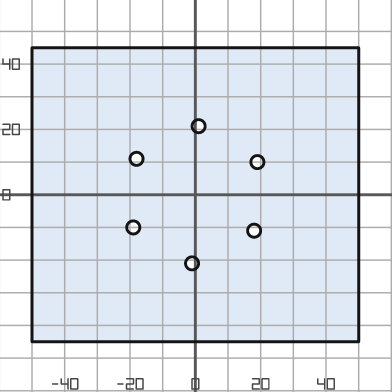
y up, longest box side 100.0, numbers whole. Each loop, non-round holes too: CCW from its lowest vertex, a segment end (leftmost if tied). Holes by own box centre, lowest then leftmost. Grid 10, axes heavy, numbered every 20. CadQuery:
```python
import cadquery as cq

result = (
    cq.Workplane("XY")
    .moveTo(-50.0, -45.0)
    .lineTo(50.0, -45.0)
    .lineTo(50.0, 45.0)
    .lineTo(-50.0, 45.0)
    .close()
    .moveTo(-1.0, -21.0)
    .circle(2.0)
    .moveTo(18.0, -11.0)
    .circle(2.0)
    .moveTo(-19.0, -10.0)
    .circle(2.0)
    .moveTo(19.0, 10.0)
    .circle(2.0)
    .moveTo(-18.0, 11.0)
    .circle(2.0)
    .moveTo(1.0, 21.0)
    .circle(2.0)
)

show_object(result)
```